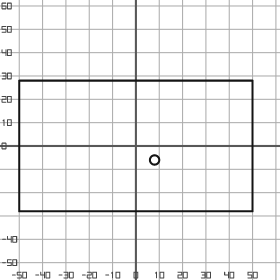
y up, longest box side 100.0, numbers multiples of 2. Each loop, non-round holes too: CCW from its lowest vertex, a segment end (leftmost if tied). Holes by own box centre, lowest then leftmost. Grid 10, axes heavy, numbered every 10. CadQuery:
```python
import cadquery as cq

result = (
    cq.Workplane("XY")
    .moveTo(-50.0, -28.0)
    .lineTo(50.0, -28.0)
    .lineTo(50.0, 28.0)
    .lineTo(-50.0, 28.0)
    .close()
    .moveTo(8.0, -6.0)
    .circle(2.0)
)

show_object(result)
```